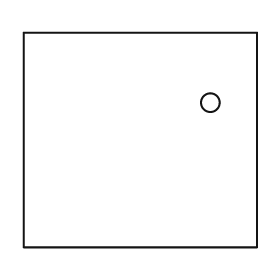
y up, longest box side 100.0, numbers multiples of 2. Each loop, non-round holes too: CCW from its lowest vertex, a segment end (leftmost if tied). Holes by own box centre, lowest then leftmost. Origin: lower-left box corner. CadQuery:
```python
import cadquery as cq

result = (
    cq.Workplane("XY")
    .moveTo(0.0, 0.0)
    .lineTo(100.0, 0.0)
    .lineTo(100.0, 92.0)
    .lineTo(0.0, 92.0)
    .close()
    .moveTo(80.0, 62.0)
    .circle(4.0)
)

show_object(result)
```